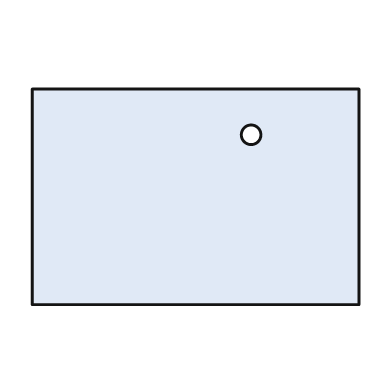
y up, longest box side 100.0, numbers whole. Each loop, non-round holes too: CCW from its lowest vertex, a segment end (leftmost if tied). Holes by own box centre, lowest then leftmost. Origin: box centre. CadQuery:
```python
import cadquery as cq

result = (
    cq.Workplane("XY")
    .moveTo(-50.0, -33.0)
    .lineTo(50.0, -33.0)
    .lineTo(50.0, 33.0)
    .lineTo(-50.0, 33.0)
    .close()
    .moveTo(17.0, 19.0)
    .circle(3.0)
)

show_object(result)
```